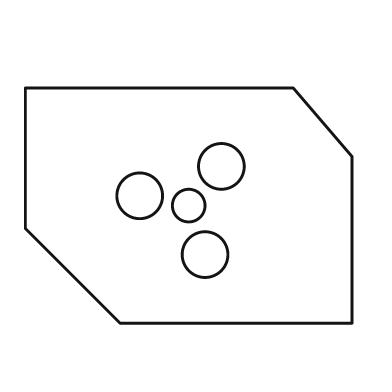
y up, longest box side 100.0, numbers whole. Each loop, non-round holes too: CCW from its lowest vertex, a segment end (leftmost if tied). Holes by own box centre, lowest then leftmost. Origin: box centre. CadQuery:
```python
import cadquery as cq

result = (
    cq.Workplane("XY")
    .moveTo(-21.0, -36.0)
    .lineTo(50.0, -36.0)
    .lineTo(50.0, 15.0)
    .lineTo(32.0, 36.0)
    .lineTo(-50.0, 36.0)
    .lineTo(-50.0, -7.0)
    .close()
    .moveTo(5.0, -15.0)
    .circle(7.0)
    .moveTo(0.0, 0.0)
    .circle(5.0)
    .moveTo(-15.0, 3.0)
    .circle(7.0)
    .moveTo(10.0, 12.0)
    .circle(7.0)
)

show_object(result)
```